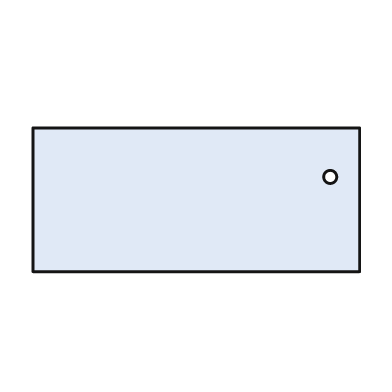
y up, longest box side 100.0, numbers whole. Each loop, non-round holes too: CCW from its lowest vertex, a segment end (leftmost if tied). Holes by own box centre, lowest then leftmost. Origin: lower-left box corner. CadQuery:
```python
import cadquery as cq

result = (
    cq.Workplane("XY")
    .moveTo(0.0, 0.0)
    .lineTo(100.0, 0.0)
    .lineTo(100.0, 44.0)
    .lineTo(0.0, 44.0)
    .close()
    .moveTo(91.0, 29.0)
    .circle(2.0)
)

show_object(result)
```